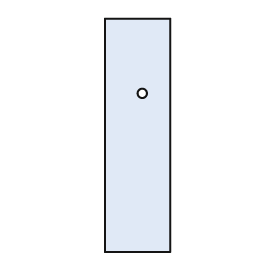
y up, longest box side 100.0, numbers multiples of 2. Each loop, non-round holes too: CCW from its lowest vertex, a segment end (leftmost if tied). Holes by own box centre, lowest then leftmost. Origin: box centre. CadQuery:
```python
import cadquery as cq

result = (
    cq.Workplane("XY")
    .moveTo(-14.0, -50.0)
    .lineTo(14.0, -50.0)
    .lineTo(14.0, 50.0)
    .lineTo(-14.0, 50.0)
    .close()
    .moveTo(2.0, 18.0)
    .circle(2.0)
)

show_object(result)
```